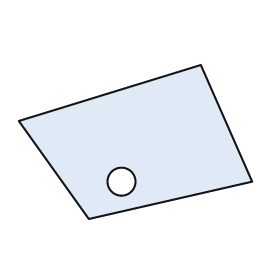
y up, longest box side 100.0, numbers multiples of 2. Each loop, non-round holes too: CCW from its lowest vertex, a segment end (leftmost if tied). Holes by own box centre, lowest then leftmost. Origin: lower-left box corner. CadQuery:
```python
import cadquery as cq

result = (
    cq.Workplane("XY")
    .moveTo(30.0, 0.0)
    .lineTo(100.0, 16.0)
    .lineTo(78.0, 66.0)
    .lineTo(0.0, 42.0)
    .close()
    .moveTo(44.0, 16.0)
    .circle(6.0)
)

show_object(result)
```